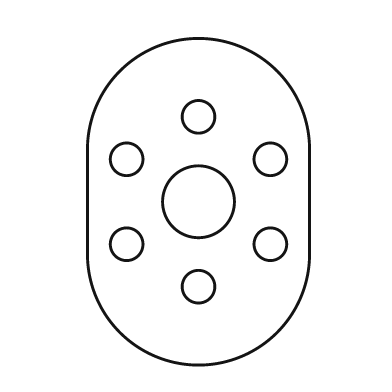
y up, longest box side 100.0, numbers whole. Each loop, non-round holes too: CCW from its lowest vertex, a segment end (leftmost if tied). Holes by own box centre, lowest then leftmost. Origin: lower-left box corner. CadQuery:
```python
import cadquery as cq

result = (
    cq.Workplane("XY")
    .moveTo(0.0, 34.0)
    .threePointArc((34.0, 0.0), (68.0, 34.0))
    .lineTo(68.0, 66.0)
    .threePointArc((34.0, 100.0), (0.0, 66.0))
    .close()
    .moveTo(34.0, 24.0)
    .circle(5.0)
    .moveTo(12.0, 37.0)
    .circle(5.0)
    .moveTo(56.0, 37.0)
    .circle(5.0)
    .moveTo(34.0, 50.0)
    .circle(11.0)
    .moveTo(12.0, 63.0)
    .circle(5.0)
    .moveTo(56.0, 63.0)
    .circle(5.0)
    .moveTo(34.0, 76.0)
    .circle(5.0)
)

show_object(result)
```